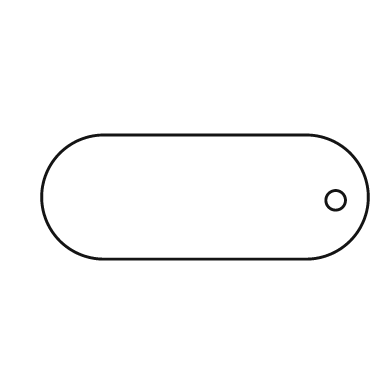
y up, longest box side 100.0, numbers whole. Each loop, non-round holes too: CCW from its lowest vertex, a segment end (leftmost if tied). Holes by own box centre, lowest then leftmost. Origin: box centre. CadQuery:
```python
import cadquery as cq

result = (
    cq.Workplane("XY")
    .moveTo(-31.0, -19.0)
    .lineTo(31.0, -19.0)
    .threePointArc((50.0, 0.0), (31.0, 19.0))
    .lineTo(-31.0, 19.0)
    .threePointArc((-50.0, 0.0), (-31.0, -19.0))
    .close()
    .moveTo(40.0, -1.0)
    .circle(3.0)
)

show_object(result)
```